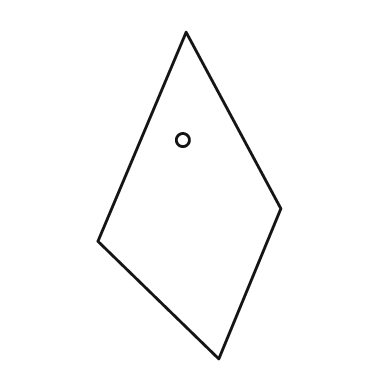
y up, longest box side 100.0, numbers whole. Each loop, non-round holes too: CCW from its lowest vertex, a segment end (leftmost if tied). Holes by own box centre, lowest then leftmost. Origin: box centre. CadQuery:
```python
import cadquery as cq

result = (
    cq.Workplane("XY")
    .moveTo(9.0, -50.0)
    .lineTo(28.0, -4.0)
    .lineTo(-1.0, 50.0)
    .lineTo(-28.0, -14.0)
    .close()
    .moveTo(-2.0, 17.0)
    .circle(2.0)
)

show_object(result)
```